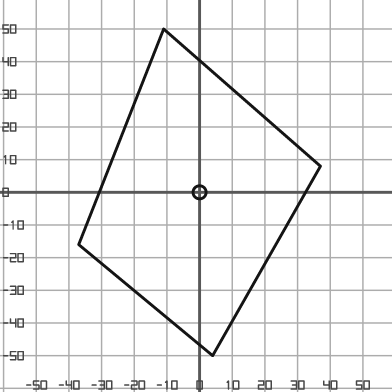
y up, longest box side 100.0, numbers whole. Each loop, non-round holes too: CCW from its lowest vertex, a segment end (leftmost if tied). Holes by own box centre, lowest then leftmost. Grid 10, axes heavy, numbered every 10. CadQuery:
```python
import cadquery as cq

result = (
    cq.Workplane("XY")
    .moveTo(4.0, -50.0)
    .lineTo(37.0, 8.0)
    .lineTo(-11.0, 50.0)
    .lineTo(-37.0, -16.0)
    .close()
    .moveTo(0.0, 0.0)
    .circle(2.0)
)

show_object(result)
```